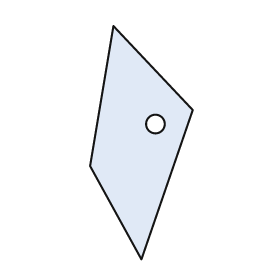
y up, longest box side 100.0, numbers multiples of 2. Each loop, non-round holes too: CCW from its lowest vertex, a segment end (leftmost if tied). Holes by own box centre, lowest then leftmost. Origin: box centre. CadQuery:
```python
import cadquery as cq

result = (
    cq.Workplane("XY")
    .moveTo(0.0, -50.0)
    .lineTo(22.0, 14.0)
    .lineTo(-12.0, 50.0)
    .lineTo(-22.0, -10.0)
    .close()
    .moveTo(6.0, 8.0)
    .circle(4.0)
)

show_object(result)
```